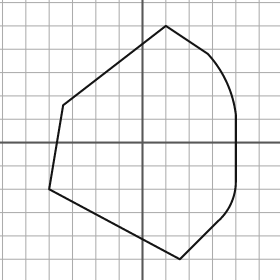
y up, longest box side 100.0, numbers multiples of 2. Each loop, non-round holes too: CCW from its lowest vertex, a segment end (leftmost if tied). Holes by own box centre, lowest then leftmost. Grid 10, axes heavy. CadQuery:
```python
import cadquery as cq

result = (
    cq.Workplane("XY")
    .moveTo(16.0, -50.0)
    .lineTo(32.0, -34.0)
    .threePointArc((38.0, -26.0), (40.0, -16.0))
    .lineTo(40.0, 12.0)
    .threePointArc((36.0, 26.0), (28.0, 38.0))
    .lineTo(10.0, 50.0)
    .lineTo(-34.0, 16.0)
    .lineTo(-40.0, -20.0)
    .close()
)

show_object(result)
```